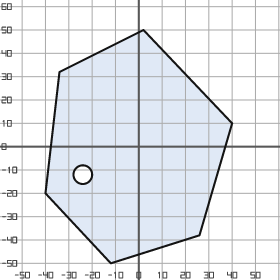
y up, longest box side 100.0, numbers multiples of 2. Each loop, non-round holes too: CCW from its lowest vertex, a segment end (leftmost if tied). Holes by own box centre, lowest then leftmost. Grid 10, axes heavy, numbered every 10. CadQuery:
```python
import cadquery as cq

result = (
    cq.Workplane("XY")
    .moveTo(-12.0, -50.0)
    .lineTo(26.0, -38.0)
    .lineTo(40.0, 10.0)
    .lineTo(2.0, 50.0)
    .lineTo(-34.0, 32.0)
    .lineTo(-40.0, -20.0)
    .close()
    .moveTo(-24.0, -12.0)
    .circle(4.0)
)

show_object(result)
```